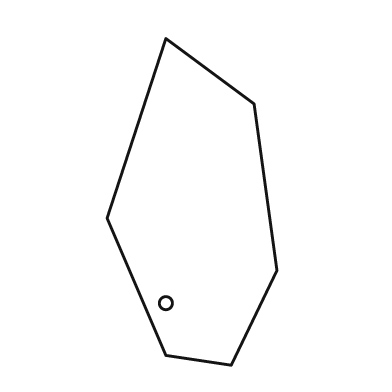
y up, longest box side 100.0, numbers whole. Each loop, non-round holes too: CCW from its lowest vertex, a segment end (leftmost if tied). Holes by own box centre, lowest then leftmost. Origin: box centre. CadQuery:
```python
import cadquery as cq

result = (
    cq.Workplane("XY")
    .moveTo(12.0, -50.0)
    .lineTo(26.0, -21.0)
    .lineTo(19.0, 30.0)
    .lineTo(-8.0, 50.0)
    .lineTo(-26.0, -5.0)
    .lineTo(-8.0, -47.0)
    .close()
    .moveTo(-8.0, -31.0)
    .circle(2.0)
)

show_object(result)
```